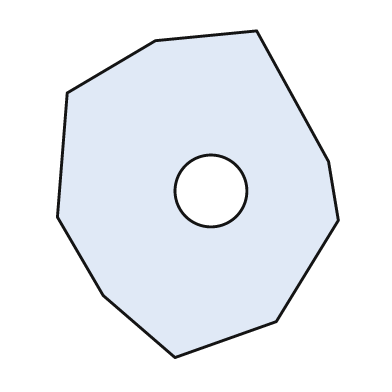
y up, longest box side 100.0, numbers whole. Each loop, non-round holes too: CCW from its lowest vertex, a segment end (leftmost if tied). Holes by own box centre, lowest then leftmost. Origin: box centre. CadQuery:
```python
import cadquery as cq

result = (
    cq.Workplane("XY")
    .moveTo(-7.0, -50.0)
    .lineTo(24.0, -39.0)
    .lineTo(43.0, -8.0)
    .lineTo(40.0, 10.0)
    .lineTo(18.0, 50.0)
    .lineTo(-13.0, 47.0)
    .lineTo(-40.0, 31.0)
    .lineTo(-43.0, -7.0)
    .lineTo(-29.0, -31.0)
    .close()
    .moveTo(4.0, 1.0)
    .circle(11.0)
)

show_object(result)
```